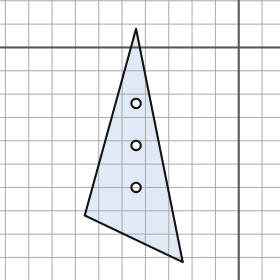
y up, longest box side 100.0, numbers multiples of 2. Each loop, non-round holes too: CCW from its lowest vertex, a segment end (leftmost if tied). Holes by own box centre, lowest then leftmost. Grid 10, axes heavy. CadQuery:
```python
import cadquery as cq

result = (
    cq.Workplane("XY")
    .moveTo(-24.0, -92.0)
    .lineTo(-44.0, 8.0)
    .lineTo(-66.0, -72.0)
    .close()
    .moveTo(-44.0, -60.0)
    .circle(2.0)
    .moveTo(-44.0, -42.0)
    .circle(2.0)
    .moveTo(-44.0, -24.0)
    .circle(2.0)
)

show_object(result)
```